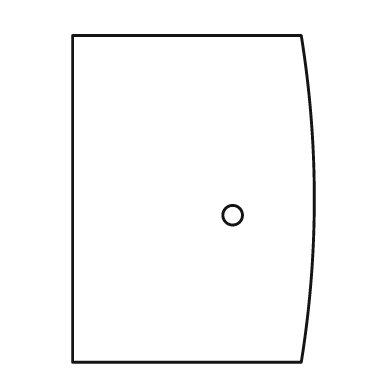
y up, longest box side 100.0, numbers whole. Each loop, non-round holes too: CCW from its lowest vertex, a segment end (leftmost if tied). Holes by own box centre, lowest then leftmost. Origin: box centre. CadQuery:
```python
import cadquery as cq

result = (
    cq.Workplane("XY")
    .moveTo(-37.0, -50.0)
    .lineTo(33.0, -50.0)
    .threePointArc((37.0, 0.0), (33.0, 50.0))
    .lineTo(-37.0, 50.0)
    .close()
    .moveTo(12.0, -5.0)
    .circle(3.0)
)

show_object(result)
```